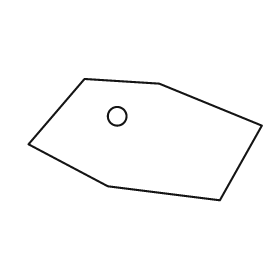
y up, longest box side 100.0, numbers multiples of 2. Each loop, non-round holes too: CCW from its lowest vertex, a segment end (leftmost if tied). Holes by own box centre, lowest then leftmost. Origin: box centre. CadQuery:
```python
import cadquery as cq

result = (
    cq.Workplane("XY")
    .moveTo(32.0, -26.0)
    .lineTo(50.0, 6.0)
    .lineTo(6.0, 24.0)
    .lineTo(-26.0, 26.0)
    .lineTo(-50.0, -2.0)
    .lineTo(-16.0, -20.0)
    .close()
    .moveTo(-12.0, 10.0)
    .circle(4.0)
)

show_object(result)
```